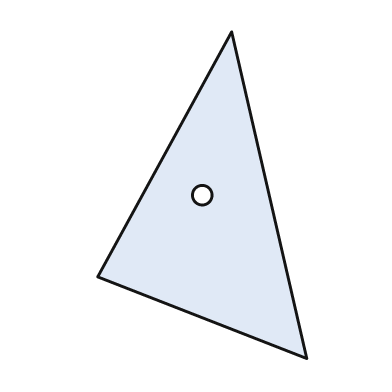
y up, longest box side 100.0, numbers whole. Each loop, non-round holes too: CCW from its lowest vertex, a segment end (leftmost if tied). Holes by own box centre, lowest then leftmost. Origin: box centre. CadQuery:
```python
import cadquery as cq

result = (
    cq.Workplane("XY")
    .moveTo(32.0, -50.0)
    .lineTo(9.0, 50.0)
    .lineTo(-32.0, -25.0)
    .close()
    .moveTo(0.0, 0.0)
    .circle(3.0)
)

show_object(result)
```